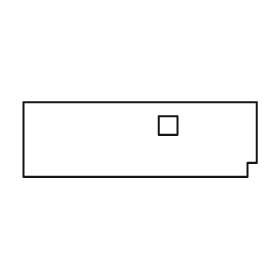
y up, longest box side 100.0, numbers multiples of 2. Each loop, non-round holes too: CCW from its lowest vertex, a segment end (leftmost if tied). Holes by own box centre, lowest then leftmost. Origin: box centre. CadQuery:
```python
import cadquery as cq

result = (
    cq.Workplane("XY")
    .moveTo(-50.0, -16.0)
    .lineTo(46.0, -16.0)
    .lineTo(46.0, -10.0)
    .lineTo(50.0, -10.0)
    .lineTo(50.0, 16.0)
    .lineTo(-50.0, 16.0)
    .close()
    .moveTo(8.0, 2.0)
    .lineTo(16.0, 2.0)
    .lineTo(16.0, 10.0)
    .lineTo(8.0, 10.0)
    .close()
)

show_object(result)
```